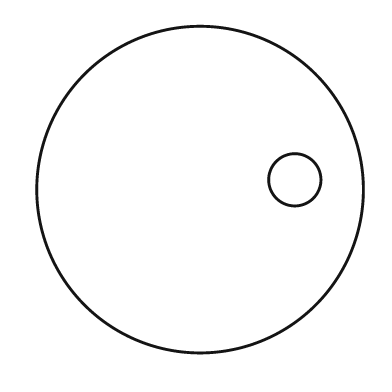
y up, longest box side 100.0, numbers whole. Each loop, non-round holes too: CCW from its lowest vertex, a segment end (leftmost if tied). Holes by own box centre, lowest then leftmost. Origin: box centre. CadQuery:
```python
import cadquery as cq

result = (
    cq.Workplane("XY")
    .moveTo(0.0, 0.0)
    .circle(50.0)
    .moveTo(29.0, 3.0)
    .circle(8.0)
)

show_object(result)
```